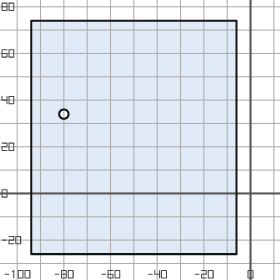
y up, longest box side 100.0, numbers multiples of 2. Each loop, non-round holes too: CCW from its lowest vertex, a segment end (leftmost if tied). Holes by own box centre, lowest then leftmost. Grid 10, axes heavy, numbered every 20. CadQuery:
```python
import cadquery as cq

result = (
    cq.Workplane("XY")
    .moveTo(-94.0, -26.0)
    .lineTo(-6.0, -26.0)
    .lineTo(-6.0, 74.0)
    .lineTo(-94.0, 74.0)
    .close()
    .moveTo(-80.0, 34.0)
    .circle(2.0)
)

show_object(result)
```